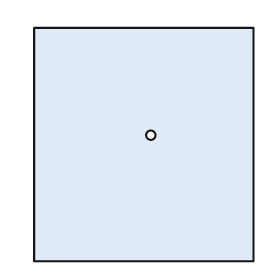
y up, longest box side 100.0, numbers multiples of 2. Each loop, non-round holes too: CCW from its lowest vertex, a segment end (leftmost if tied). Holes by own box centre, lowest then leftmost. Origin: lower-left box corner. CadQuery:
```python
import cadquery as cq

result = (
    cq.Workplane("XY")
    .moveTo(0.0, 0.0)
    .lineTo(94.0, 0.0)
    .lineTo(94.0, 100.0)
    .lineTo(0.0, 100.0)
    .close()
    .moveTo(50.0, 54.0)
    .circle(2.0)
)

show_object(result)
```